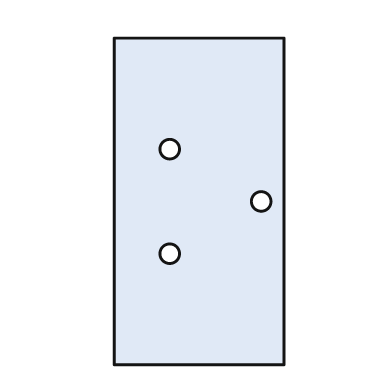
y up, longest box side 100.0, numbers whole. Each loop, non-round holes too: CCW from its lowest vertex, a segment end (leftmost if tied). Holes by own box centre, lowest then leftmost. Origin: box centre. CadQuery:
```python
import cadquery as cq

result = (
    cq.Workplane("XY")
    .moveTo(-26.0, -50.0)
    .lineTo(26.0, -50.0)
    .lineTo(26.0, 50.0)
    .lineTo(-26.0, 50.0)
    .close()
    .moveTo(-9.0, -16.0)
    .circle(3.0)
    .moveTo(19.0, 0.0)
    .circle(3.0)
    .moveTo(-9.0, 16.0)
    .circle(3.0)
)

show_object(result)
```